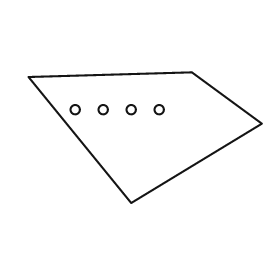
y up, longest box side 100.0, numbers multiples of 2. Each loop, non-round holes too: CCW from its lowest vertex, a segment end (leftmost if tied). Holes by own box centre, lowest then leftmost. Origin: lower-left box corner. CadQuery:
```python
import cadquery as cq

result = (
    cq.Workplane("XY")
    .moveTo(44.0, 0.0)
    .lineTo(100.0, 34.0)
    .lineTo(70.0, 56.0)
    .lineTo(0.0, 54.0)
    .close()
    .moveTo(20.0, 40.0)
    .circle(2.0)
    .moveTo(32.0, 40.0)
    .circle(2.0)
    .moveTo(44.0, 40.0)
    .circle(2.0)
    .moveTo(56.0, 40.0)
    .circle(2.0)
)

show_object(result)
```